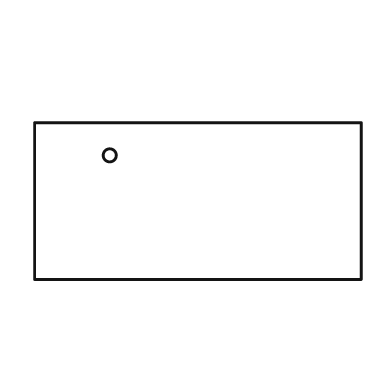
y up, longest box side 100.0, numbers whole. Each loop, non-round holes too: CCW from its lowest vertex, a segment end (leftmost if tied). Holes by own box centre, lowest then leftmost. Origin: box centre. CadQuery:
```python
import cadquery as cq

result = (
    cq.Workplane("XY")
    .moveTo(-50.0, -24.0)
    .lineTo(50.0, -24.0)
    .lineTo(50.0, 24.0)
    .lineTo(-50.0, 24.0)
    .close()
    .moveTo(-27.0, 14.0)
    .circle(2.0)
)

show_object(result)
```